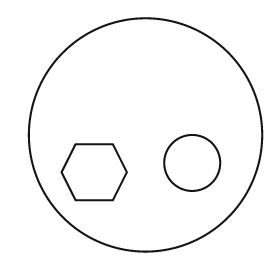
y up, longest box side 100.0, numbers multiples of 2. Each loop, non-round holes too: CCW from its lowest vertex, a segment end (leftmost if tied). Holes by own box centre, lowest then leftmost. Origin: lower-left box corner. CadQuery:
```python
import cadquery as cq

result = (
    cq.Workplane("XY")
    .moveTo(50.0, 50.0)
    .circle(50.0)
    .moveTo(20.0, 22.0)
    .lineTo(36.0, 22.0)
    .lineTo(42.0, 34.0)
    .lineTo(36.0, 46.0)
    .lineTo(20.0, 46.0)
    .lineTo(14.0, 34.0)
    .close()
    .moveTo(70.0, 38.0)
    .circle(12.0)
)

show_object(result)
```